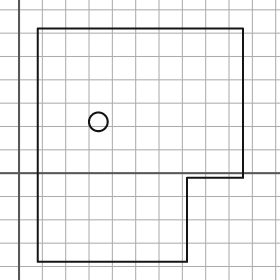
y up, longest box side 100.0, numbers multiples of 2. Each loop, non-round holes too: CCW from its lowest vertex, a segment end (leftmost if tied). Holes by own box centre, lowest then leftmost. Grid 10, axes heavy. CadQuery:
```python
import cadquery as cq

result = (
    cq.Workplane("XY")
    .moveTo(8.0, -38.0)
    .lineTo(72.0, -38.0)
    .lineTo(72.0, -2.0)
    .lineTo(96.0, -2.0)
    .lineTo(96.0, 62.0)
    .lineTo(8.0, 62.0)
    .close()
    .moveTo(34.0, 22.0)
    .circle(4.0)
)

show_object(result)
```